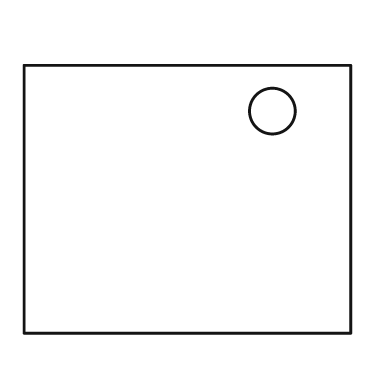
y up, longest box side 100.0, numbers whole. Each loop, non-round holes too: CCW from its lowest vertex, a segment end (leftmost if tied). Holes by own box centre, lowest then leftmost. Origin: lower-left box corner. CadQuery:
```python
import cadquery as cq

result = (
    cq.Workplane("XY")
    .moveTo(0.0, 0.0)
    .lineTo(100.0, 0.0)
    .lineTo(100.0, 82.0)
    .lineTo(0.0, 82.0)
    .close()
    .moveTo(76.0, 68.0)
    .circle(7.0)
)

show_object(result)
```